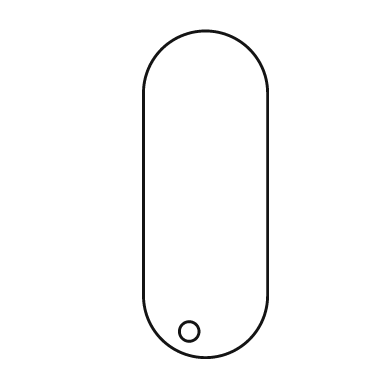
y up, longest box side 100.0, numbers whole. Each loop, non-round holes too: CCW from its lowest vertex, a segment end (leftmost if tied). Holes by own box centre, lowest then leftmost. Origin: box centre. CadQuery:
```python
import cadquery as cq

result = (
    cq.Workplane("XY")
    .moveTo(-19.0, -31.0)
    .threePointArc((0.0, -50.0), (19.0, -31.0))
    .lineTo(19.0, 31.0)
    .threePointArc((0.0, 50.0), (-19.0, 31.0))
    .close()
    .moveTo(-5.0, -42.0)
    .circle(3.0)
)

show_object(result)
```